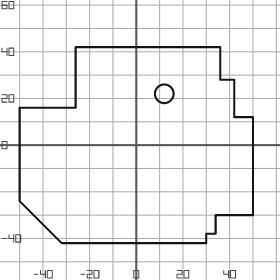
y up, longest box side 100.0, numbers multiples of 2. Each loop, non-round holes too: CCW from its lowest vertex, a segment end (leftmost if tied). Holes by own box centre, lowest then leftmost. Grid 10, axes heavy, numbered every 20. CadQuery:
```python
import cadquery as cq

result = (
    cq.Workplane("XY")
    .moveTo(-32.0, -42.0)
    .lineTo(30.0, -42.0)
    .lineTo(30.0, -38.0)
    .lineTo(34.0, -38.0)
    .lineTo(34.0, -30.0)
    .lineTo(50.0, -30.0)
    .lineTo(50.0, 12.0)
    .lineTo(42.0, 12.0)
    .lineTo(42.0, 28.0)
    .lineTo(36.0, 28.0)
    .lineTo(36.0, 42.0)
    .lineTo(-26.0, 42.0)
    .lineTo(-26.0, 16.0)
    .lineTo(-50.0, 16.0)
    .lineTo(-50.0, -24.0)
    .close()
    .moveTo(12.0, 22.0)
    .circle(4.0)
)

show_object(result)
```